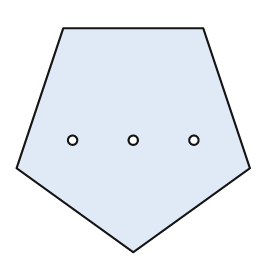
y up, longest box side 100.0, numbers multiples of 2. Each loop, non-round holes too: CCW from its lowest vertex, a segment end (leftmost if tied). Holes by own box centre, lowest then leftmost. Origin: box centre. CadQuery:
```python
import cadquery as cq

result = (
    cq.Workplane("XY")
    .moveTo(0.0, -48.0)
    .lineTo(50.0, -12.0)
    .lineTo(30.0, 48.0)
    .lineTo(-30.0, 48.0)
    .lineTo(-50.0, -12.0)
    .close()
    .moveTo(-26.0, 0.0)
    .circle(2.0)
    .moveTo(0.0, 0.0)
    .circle(2.0)
    .moveTo(26.0, 0.0)
    .circle(2.0)
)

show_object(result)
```